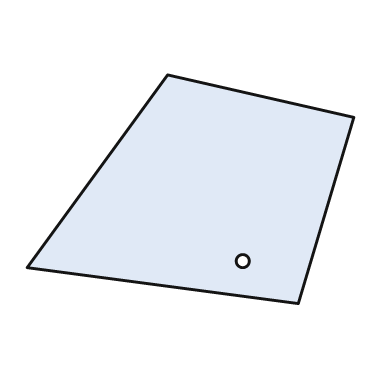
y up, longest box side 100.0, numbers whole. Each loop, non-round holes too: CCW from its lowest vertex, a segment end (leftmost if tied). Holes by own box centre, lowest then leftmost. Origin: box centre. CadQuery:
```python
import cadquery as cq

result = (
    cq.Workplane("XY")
    .moveTo(33.0, -35.0)
    .lineTo(50.0, 22.0)
    .lineTo(-7.0, 35.0)
    .lineTo(-50.0, -24.0)
    .close()
    .moveTo(16.0, -22.0)
    .circle(2.0)
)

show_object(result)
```